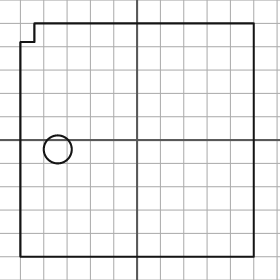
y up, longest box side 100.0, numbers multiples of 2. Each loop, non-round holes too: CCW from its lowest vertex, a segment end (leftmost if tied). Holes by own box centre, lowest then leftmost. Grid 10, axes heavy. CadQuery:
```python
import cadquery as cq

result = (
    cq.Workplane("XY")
    .moveTo(-50.0, -50.0)
    .lineTo(50.0, -50.0)
    .lineTo(50.0, 50.0)
    .lineTo(-44.0, 50.0)
    .lineTo(-44.0, 42.0)
    .lineTo(-50.0, 42.0)
    .close()
    .moveTo(-34.0, -4.0)
    .circle(6.0)
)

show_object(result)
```